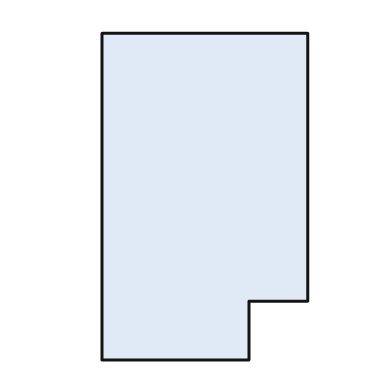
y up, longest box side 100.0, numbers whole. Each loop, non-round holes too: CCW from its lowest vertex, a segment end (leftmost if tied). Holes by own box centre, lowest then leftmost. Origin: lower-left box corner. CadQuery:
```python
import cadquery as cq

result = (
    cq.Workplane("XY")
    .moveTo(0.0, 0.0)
    .lineTo(45.0, 0.0)
    .lineTo(45.0, 18.0)
    .lineTo(63.0, 18.0)
    .lineTo(63.0, 100.0)
    .lineTo(0.0, 100.0)
    .close()
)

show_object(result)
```